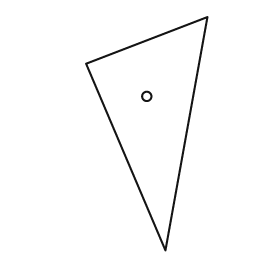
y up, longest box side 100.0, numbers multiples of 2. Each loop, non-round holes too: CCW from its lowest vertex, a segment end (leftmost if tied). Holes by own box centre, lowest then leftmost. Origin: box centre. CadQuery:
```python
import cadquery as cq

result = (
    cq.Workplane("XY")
    .moveTo(8.0, -50.0)
    .lineTo(26.0, 50.0)
    .lineTo(-26.0, 30.0)
    .close()
    .moveTo(0.0, 16.0)
    .circle(2.0)
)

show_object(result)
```